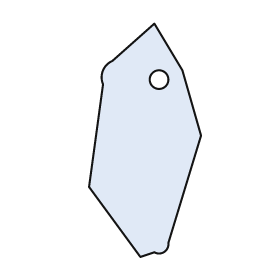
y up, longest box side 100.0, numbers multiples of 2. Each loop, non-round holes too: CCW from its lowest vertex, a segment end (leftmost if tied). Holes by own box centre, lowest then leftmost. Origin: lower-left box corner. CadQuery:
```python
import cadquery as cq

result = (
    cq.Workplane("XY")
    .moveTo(22.0, 0.0)
    .lineTo(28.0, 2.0)
    .threePointArc((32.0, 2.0), (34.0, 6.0))
    .lineTo(48.0, 52.0)
    .lineTo(40.0, 80.0)
    .lineTo(28.0, 100.0)
    .lineTo(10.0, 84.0)
    .threePointArc((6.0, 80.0), (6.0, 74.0))
    .lineTo(0.0, 30.0)
    .close()
    .moveTo(30.0, 76.0)
    .circle(4.0)
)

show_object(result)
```